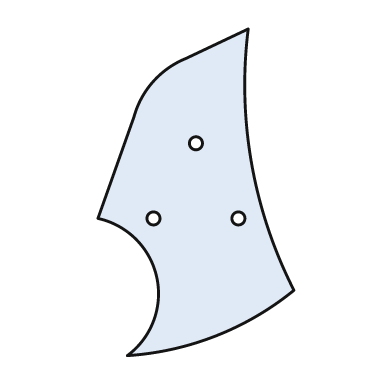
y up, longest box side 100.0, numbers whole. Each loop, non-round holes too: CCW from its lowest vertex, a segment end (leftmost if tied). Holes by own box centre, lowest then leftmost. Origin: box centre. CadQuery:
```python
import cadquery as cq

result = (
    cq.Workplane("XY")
    .moveTo(-21.0, -50.0)
    .threePointArc((6.0, -44.0), (30.0, -30.0))
    .threePointArc((17.0, 9.0), (16.0, 50.0))
    .lineTo(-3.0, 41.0)
    .threePointArc((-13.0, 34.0), (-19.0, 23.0))
    .lineTo(-30.0, -8.0)
    .threePointArc((-12.0, -26.0), (-21.0, -50.0))
    .close()
    .moveTo(-13.0, -8.0)
    .circle(2.0)
    .moveTo(13.0, -8.0)
    .circle(2.0)
    .moveTo(0.0, 15.0)
    .circle(2.0)
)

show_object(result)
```